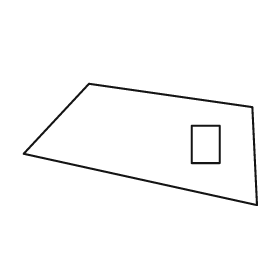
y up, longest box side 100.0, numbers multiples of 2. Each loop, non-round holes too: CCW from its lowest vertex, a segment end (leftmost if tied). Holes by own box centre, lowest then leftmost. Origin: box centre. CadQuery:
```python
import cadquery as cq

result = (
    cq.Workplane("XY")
    .moveTo(50.0, -26.0)
    .lineTo(48.0, 16.0)
    .lineTo(-22.0, 26.0)
    .lineTo(-50.0, -4.0)
    .close()
    .moveTo(22.0, -8.0)
    .lineTo(34.0, -8.0)
    .lineTo(34.0, 8.0)
    .lineTo(22.0, 8.0)
    .close()
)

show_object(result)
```